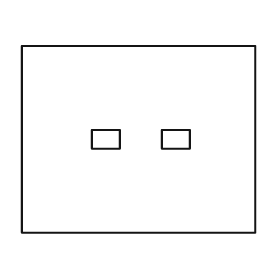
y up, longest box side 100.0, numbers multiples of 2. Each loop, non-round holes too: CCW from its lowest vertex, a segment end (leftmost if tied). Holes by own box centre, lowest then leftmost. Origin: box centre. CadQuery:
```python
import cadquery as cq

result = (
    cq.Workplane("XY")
    .moveTo(-50.0, -40.0)
    .lineTo(50.0, -40.0)
    .lineTo(50.0, 40.0)
    .lineTo(-50.0, 40.0)
    .close()
    .moveTo(-20.0, -4.0)
    .lineTo(-8.0, -4.0)
    .lineTo(-8.0, 4.0)
    .lineTo(-20.0, 4.0)
    .close()
    .moveTo(10.0, -4.0)
    .lineTo(22.0, -4.0)
    .lineTo(22.0, 4.0)
    .lineTo(10.0, 4.0)
    .close()
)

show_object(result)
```